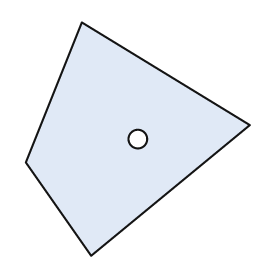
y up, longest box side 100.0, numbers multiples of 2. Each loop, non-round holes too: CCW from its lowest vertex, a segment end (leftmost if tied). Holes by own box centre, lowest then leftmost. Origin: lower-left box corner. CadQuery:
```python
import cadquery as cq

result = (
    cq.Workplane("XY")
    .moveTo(28.0, 0.0)
    .lineTo(96.0, 56.0)
    .lineTo(24.0, 100.0)
    .lineTo(0.0, 40.0)
    .close()
    .moveTo(48.0, 50.0)
    .circle(4.0)
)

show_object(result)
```